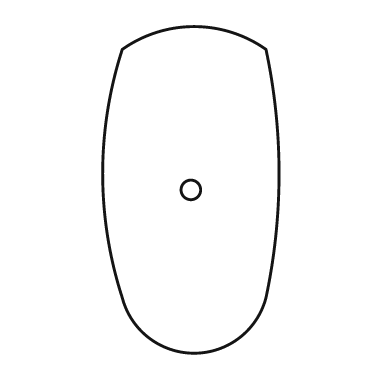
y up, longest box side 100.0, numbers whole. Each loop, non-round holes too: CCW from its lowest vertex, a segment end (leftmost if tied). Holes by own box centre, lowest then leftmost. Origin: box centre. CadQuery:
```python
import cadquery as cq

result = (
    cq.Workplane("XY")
    .moveTo(-21.0, -33.0)
    .threePointArc((1.0, -50.0), (23.0, -33.0))
    .threePointArc((27.0, 5.0), (23.0, 43.0))
    .threePointArc((1.0, 50.0), (-21.0, 43.0))
    .threePointArc((-27.0, 5.0), (-21.0, -33.0))
    .close()
    .moveTo(0.0, 0.0)
    .circle(3.0)
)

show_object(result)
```